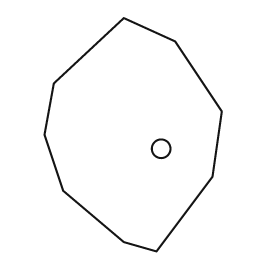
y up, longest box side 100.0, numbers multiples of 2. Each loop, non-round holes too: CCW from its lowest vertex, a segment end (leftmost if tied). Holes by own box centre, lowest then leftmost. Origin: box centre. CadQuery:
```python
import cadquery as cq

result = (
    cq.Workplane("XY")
    .moveTo(10.0, -50.0)
    .lineTo(34.0, -18.0)
    .lineTo(38.0, 10.0)
    .lineTo(18.0, 40.0)
    .lineTo(-4.0, 50.0)
    .lineTo(-34.0, 22.0)
    .lineTo(-38.0, 0.0)
    .lineTo(-30.0, -24.0)
    .lineTo(-4.0, -46.0)
    .close()
    .moveTo(12.0, -6.0)
    .circle(4.0)
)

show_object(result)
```